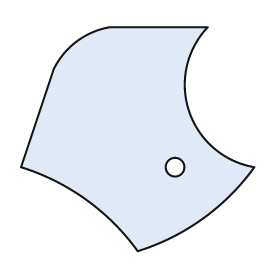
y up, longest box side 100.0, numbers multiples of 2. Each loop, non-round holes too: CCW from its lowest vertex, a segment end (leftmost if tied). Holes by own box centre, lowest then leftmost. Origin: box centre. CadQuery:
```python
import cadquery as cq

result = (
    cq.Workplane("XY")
    .moveTo(0.0, -48.0)
    .threePointArc((28.0, -34.0), (50.0, -12.0))
    .threePointArc((22.0, 12.0), (30.0, 48.0))
    .lineTo(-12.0, 48.0)
    .threePointArc((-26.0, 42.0), (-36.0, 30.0))
    .lineTo(-50.0, -12.0)
    .threePointArc((-22.0, -26.0), (0.0, -48.0))
    .close()
    .moveTo(16.0, -12.0)
    .circle(4.0)
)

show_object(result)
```